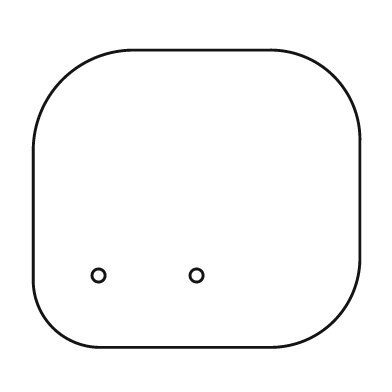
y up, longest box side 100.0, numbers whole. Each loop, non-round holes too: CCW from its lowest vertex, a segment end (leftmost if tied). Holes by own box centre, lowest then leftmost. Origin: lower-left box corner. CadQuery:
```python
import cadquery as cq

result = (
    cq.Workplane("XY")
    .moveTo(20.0, 0.0)
    .lineTo(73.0, 0.0)
    .threePointArc((92.0, 8.0), (100.0, 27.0))
    .lineTo(100.0, 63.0)
    .threePointArc((92.0, 83.0), (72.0, 91.0))
    .lineTo(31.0, 91.0)
    .threePointArc((9.0, 82.0), (0.0, 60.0))
    .lineTo(0.0, 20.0)
    .threePointArc((6.0, 6.0), (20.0, 0.0))
    .close()
    .moveTo(20.0, 22.0)
    .circle(2.0)
    .moveTo(50.0, 22.0)
    .circle(2.0)
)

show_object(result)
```